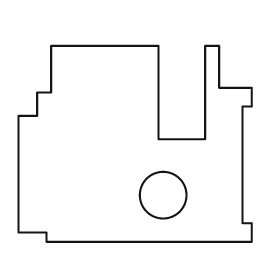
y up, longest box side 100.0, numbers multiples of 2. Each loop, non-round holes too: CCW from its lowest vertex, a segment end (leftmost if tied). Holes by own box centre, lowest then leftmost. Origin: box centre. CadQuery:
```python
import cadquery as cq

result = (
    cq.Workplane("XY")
    .moveTo(-38.0, -42.0)
    .lineTo(50.0, -42.0)
    .lineTo(50.0, -34.0)
    .lineTo(46.0, -34.0)
    .lineTo(46.0, 16.0)
    .lineTo(50.0, 16.0)
    .lineTo(50.0, 24.0)
    .lineTo(36.0, 24.0)
    .lineTo(36.0, 42.0)
    .lineTo(30.0, 42.0)
    .lineTo(30.0, 2.0)
    .lineTo(10.0, 2.0)
    .lineTo(10.0, 42.0)
    .lineTo(-36.0, 42.0)
    .lineTo(-36.0, 22.0)
    .lineTo(-42.0, 22.0)
    .lineTo(-42.0, 12.0)
    .lineTo(-50.0, 12.0)
    .lineTo(-50.0, -38.0)
    .lineTo(-38.0, -38.0)
    .close()
    .moveTo(12.0, -22.0)
    .circle(10.0)
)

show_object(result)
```